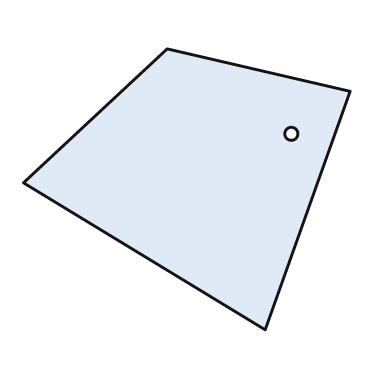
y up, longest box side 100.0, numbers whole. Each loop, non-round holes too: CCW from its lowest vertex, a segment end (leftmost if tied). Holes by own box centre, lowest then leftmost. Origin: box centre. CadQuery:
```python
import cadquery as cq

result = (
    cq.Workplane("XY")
    .moveTo(24.0, -43.0)
    .lineTo(50.0, 30.0)
    .lineTo(-6.0, 43.0)
    .lineTo(-50.0, 2.0)
    .close()
    .moveTo(32.0, 17.0)
    .circle(2.0)
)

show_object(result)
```